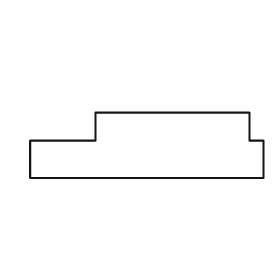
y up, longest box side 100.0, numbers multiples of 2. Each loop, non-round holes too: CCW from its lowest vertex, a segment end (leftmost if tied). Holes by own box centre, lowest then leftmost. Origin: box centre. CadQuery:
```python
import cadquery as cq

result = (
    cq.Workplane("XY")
    .moveTo(-50.0, -14.0)
    .lineTo(50.0, -14.0)
    .lineTo(50.0, 2.0)
    .lineTo(44.0, 2.0)
    .lineTo(44.0, 14.0)
    .lineTo(-22.0, 14.0)
    .lineTo(-22.0, 2.0)
    .lineTo(-50.0, 2.0)
    .close()
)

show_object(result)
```